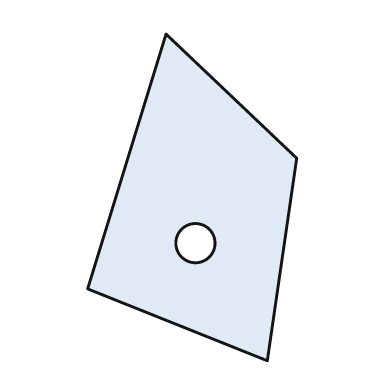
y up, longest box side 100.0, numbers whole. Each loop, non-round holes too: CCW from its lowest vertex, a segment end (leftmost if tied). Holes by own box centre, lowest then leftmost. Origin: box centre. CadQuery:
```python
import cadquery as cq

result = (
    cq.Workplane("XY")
    .moveTo(23.0, -50.0)
    .lineTo(32.0, 12.0)
    .lineTo(-8.0, 50.0)
    .lineTo(-32.0, -28.0)
    .close()
    .moveTo(1.0, -14.0)
    .circle(6.0)
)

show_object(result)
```